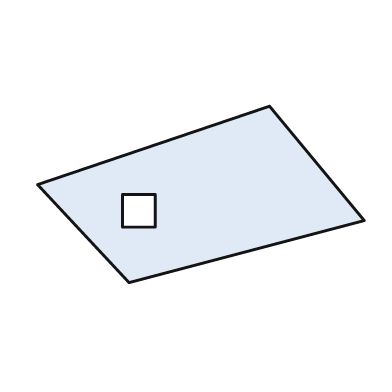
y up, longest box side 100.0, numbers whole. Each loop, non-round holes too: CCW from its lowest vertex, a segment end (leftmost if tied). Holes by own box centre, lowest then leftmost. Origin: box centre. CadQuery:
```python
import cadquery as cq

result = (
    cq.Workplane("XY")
    .moveTo(-22.0, -27.0)
    .lineTo(50.0, -8.0)
    .lineTo(21.0, 27.0)
    .lineTo(-50.0, 3.0)
    .close()
    .moveTo(-24.0, -10.0)
    .lineTo(-14.0, -10.0)
    .lineTo(-14.0, 0.0)
    .lineTo(-24.0, 0.0)
    .close()
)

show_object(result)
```